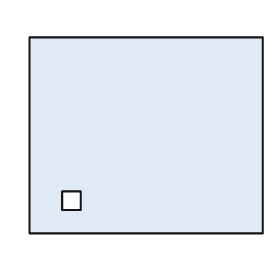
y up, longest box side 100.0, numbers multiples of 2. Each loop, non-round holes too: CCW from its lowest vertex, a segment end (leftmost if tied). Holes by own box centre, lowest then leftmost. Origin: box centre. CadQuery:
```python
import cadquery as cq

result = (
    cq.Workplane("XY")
    .moveTo(-50.0, -42.0)
    .lineTo(50.0, -42.0)
    .lineTo(50.0, 42.0)
    .lineTo(-50.0, 42.0)
    .close()
    .moveTo(-36.0, -32.0)
    .lineTo(-28.0, -32.0)
    .lineTo(-28.0, -24.0)
    .lineTo(-36.0, -24.0)
    .close()
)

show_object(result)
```